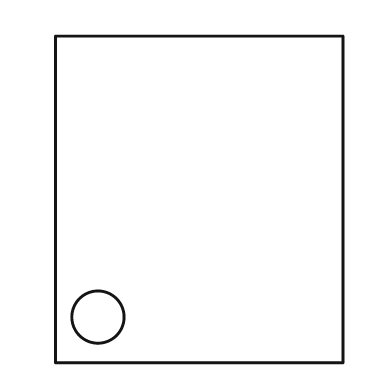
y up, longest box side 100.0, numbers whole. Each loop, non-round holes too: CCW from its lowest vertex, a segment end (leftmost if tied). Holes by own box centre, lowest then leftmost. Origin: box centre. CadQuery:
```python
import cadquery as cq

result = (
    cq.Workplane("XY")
    .moveTo(-44.0, -50.0)
    .lineTo(44.0, -50.0)
    .lineTo(44.0, 50.0)
    .lineTo(-44.0, 50.0)
    .close()
    .moveTo(-31.0, -36.0)
    .circle(8.0)
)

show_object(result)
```